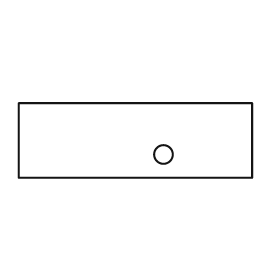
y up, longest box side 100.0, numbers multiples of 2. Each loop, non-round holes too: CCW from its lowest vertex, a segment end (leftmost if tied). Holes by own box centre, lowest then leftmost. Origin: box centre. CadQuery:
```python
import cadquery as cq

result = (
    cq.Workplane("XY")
    .moveTo(-50.0, -16.0)
    .lineTo(50.0, -16.0)
    .lineTo(50.0, 16.0)
    .lineTo(-50.0, 16.0)
    .close()
    .moveTo(12.0, -6.0)
    .circle(4.0)
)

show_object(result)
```